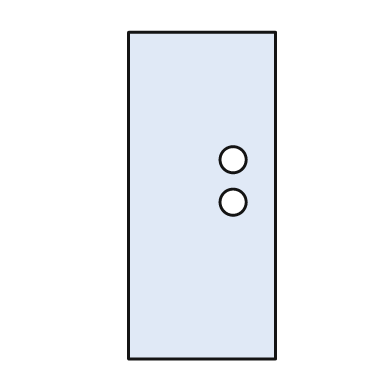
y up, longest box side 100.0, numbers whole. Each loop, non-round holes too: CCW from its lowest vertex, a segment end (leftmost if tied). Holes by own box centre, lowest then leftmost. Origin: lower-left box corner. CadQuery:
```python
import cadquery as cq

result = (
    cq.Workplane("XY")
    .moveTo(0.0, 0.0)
    .lineTo(45.0, 0.0)
    .lineTo(45.0, 100.0)
    .lineTo(0.0, 100.0)
    .close()
    .moveTo(32.0, 48.0)
    .circle(4.0)
    .moveTo(32.0, 61.0)
    .circle(4.0)
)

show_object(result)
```